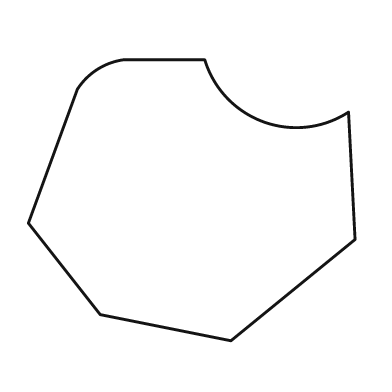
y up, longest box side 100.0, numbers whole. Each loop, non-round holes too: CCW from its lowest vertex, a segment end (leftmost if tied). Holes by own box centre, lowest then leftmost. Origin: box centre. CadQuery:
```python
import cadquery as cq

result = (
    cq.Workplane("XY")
    .moveTo(12.0, -43.0)
    .lineTo(50.0, -12.0)
    .lineTo(48.0, 27.0)
    .threePointArc((22.0, 24.0), (4.0, 43.0))
    .lineTo(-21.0, 43.0)
    .threePointArc((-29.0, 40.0), (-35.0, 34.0))
    .lineTo(-50.0, -7.0)
    .lineTo(-28.0, -35.0)
    .close()
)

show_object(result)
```